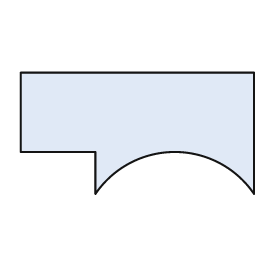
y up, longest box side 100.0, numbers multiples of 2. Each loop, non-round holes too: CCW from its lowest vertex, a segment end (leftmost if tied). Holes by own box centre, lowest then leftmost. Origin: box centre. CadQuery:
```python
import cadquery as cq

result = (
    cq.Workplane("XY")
    .moveTo(-18.0, -26.0)
    .threePointArc((16.0, -8.0), (50.0, -26.0))
    .lineTo(50.0, 26.0)
    .lineTo(-50.0, 26.0)
    .lineTo(-50.0, -8.0)
    .lineTo(-18.0, -8.0)
    .close()
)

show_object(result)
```